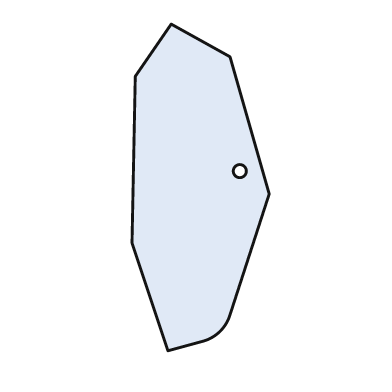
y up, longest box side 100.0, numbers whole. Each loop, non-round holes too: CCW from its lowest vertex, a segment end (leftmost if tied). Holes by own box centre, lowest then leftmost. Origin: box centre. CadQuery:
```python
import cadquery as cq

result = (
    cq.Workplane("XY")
    .moveTo(-10.0, -50.0)
    .lineTo(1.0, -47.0)
    .threePointArc((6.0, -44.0), (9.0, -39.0))
    .lineTo(21.0, -2.0)
    .lineTo(9.0, 40.0)
    .lineTo(-9.0, 50.0)
    .lineTo(-20.0, 34.0)
    .lineTo(-21.0, -17.0)
    .close()
    .moveTo(12.0, 5.0)
    .circle(2.0)
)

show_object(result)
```